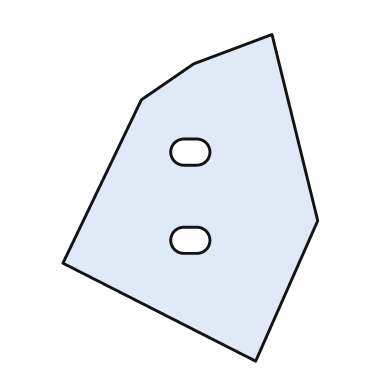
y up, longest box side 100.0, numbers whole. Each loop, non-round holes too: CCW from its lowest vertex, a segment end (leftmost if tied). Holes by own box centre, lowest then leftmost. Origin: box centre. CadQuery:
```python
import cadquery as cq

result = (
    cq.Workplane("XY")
    .moveTo(20.0, -50.0)
    .lineTo(39.0, -7.0)
    .lineTo(25.0, 50.0)
    .lineTo(1.0, 41.0)
    .lineTo(-15.0, 30.0)
    .lineTo(-39.0, -20.0)
    .close()
    .moveTo(-2.0, -17.0)
    .lineTo(2.0, -17.0)
    .threePointArc((6.0, -13.0), (2.0, -9.0))
    .lineTo(-2.0, -9.0)
    .threePointArc((-6.0, -13.0), (-2.0, -17.0))
    .close()
    .moveTo(-2.0, 10.0)
    .lineTo(2.0, 10.0)
    .threePointArc((6.0, 14.0), (2.0, 18.0))
    .lineTo(-2.0, 18.0)
    .threePointArc((-6.0, 14.0), (-2.0, 10.0))
    .close()
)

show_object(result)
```